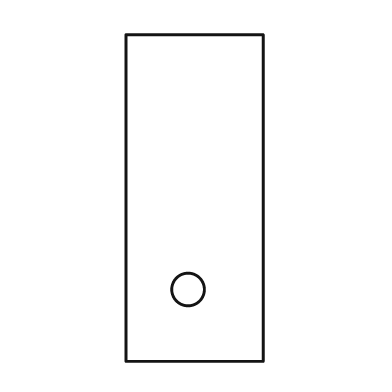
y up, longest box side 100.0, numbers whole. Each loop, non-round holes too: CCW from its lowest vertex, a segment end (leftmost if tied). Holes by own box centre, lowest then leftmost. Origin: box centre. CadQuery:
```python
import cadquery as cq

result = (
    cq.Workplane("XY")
    .moveTo(-21.0, -50.0)
    .lineTo(21.0, -50.0)
    .lineTo(21.0, 50.0)
    .lineTo(-21.0, 50.0)
    .close()
    .moveTo(-2.0, -28.0)
    .circle(5.0)
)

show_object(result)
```